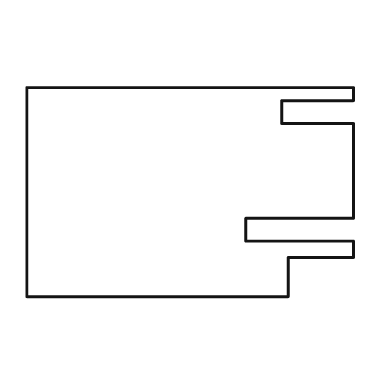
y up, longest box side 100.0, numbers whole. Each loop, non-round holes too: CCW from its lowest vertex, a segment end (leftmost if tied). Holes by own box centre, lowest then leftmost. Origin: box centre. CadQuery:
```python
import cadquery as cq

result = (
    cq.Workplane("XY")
    .moveTo(-50.0, -32.0)
    .lineTo(30.0, -32.0)
    .lineTo(30.0, -20.0)
    .lineTo(50.0, -20.0)
    .lineTo(50.0, -15.0)
    .lineTo(17.0, -15.0)
    .lineTo(17.0, -8.0)
    .lineTo(50.0, -8.0)
    .lineTo(50.0, 21.0)
    .lineTo(28.0, 21.0)
    .lineTo(28.0, 28.0)
    .lineTo(50.0, 28.0)
    .lineTo(50.0, 32.0)
    .lineTo(-50.0, 32.0)
    .close()
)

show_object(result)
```